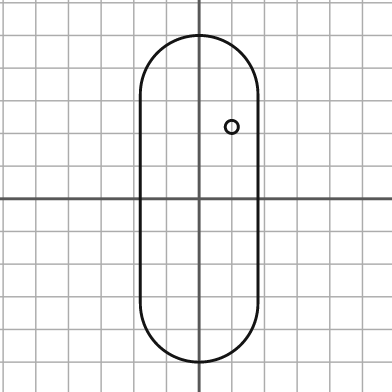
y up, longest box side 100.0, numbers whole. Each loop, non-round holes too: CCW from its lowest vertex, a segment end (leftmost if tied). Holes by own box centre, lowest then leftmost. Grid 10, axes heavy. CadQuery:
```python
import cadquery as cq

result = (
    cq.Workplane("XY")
    .moveTo(-18.0, -32.0)
    .threePointArc((0.0, -50.0), (18.0, -32.0))
    .lineTo(18.0, 32.0)
    .threePointArc((0.0, 50.0), (-18.0, 32.0))
    .close()
    .moveTo(10.0, 22.0)
    .circle(2.0)
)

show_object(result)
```